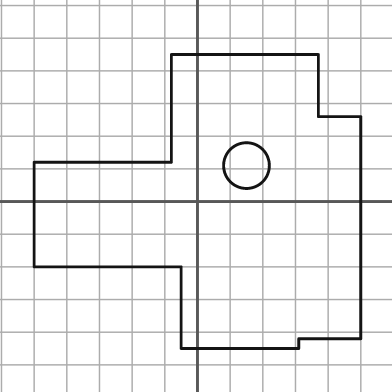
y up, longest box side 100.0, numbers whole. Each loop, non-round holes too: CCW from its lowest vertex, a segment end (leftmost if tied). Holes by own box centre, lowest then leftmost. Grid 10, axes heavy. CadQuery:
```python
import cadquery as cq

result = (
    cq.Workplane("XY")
    .moveTo(-5.0, -45.0)
    .lineTo(31.0, -45.0)
    .lineTo(31.0, -42.0)
    .lineTo(50.0, -42.0)
    .lineTo(50.0, 26.0)
    .lineTo(37.0, 26.0)
    .lineTo(37.0, 45.0)
    .lineTo(-8.0, 45.0)
    .lineTo(-8.0, 12.0)
    .lineTo(-50.0, 12.0)
    .lineTo(-50.0, -20.0)
    .lineTo(-5.0, -20.0)
    .close()
    .moveTo(15.0, 11.0)
    .circle(7.0)
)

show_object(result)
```